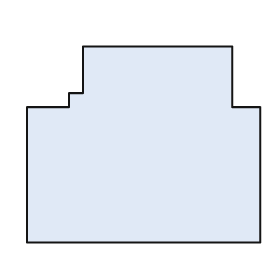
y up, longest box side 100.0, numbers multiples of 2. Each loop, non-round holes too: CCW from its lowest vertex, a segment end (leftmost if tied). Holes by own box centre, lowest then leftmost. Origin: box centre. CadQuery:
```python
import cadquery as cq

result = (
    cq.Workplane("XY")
    .moveTo(-50.0, -42.0)
    .lineTo(50.0, -42.0)
    .lineTo(50.0, 16.0)
    .lineTo(38.0, 16.0)
    .lineTo(38.0, 42.0)
    .lineTo(-26.0, 42.0)
    .lineTo(-26.0, 22.0)
    .lineTo(-32.0, 22.0)
    .lineTo(-32.0, 16.0)
    .lineTo(-50.0, 16.0)
    .close()
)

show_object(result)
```